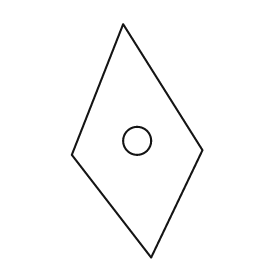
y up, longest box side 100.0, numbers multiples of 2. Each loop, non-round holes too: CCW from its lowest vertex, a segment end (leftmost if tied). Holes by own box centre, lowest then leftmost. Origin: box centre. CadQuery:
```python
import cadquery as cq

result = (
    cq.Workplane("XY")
    .moveTo(6.0, -50.0)
    .lineTo(28.0, -4.0)
    .lineTo(-6.0, 50.0)
    .lineTo(-28.0, -6.0)
    .close()
    .moveTo(0.0, 0.0)
    .circle(6.0)
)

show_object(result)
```